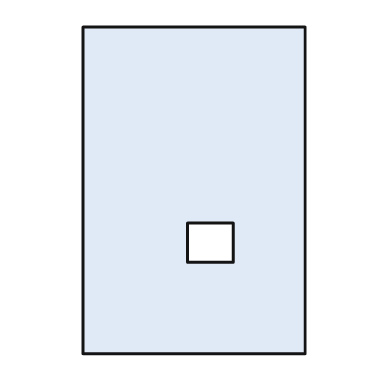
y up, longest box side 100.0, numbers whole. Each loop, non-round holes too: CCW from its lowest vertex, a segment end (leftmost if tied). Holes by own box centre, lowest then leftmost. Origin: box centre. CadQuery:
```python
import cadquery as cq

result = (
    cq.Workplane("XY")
    .moveTo(-34.0, -50.0)
    .lineTo(34.0, -50.0)
    .lineTo(34.0, 50.0)
    .lineTo(-34.0, 50.0)
    .close()
    .moveTo(-2.0, -22.0)
    .lineTo(12.0, -22.0)
    .lineTo(12.0, -10.0)
    .lineTo(-2.0, -10.0)
    .close()
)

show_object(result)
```